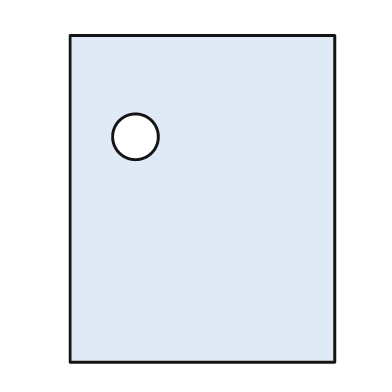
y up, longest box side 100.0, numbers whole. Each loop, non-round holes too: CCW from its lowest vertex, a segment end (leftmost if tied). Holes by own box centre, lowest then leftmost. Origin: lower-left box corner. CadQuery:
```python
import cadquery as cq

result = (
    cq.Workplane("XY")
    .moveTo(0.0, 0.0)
    .lineTo(81.0, 0.0)
    .lineTo(81.0, 100.0)
    .lineTo(0.0, 100.0)
    .close()
    .moveTo(20.0, 69.0)
    .circle(7.0)
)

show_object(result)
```